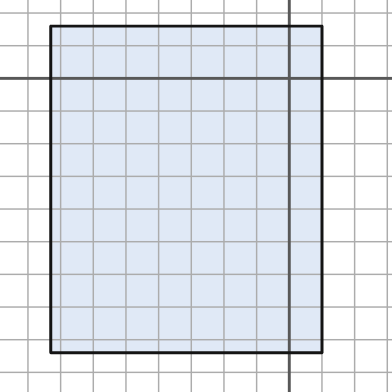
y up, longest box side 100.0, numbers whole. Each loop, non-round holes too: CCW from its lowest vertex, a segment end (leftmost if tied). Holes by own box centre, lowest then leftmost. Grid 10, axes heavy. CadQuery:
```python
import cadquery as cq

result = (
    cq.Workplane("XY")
    .moveTo(-73.0, -84.0)
    .lineTo(10.0, -84.0)
    .lineTo(10.0, 16.0)
    .lineTo(-73.0, 16.0)
    .close()
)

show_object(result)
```